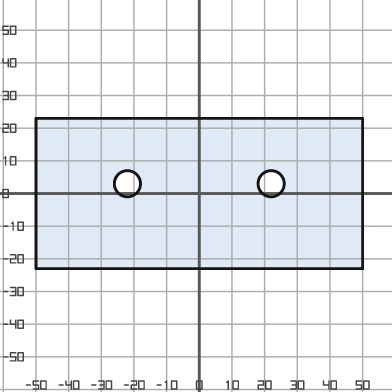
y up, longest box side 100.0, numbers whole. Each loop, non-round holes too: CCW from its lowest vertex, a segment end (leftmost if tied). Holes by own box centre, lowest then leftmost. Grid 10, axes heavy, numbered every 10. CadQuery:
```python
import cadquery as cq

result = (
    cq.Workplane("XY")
    .moveTo(-50.0, -23.0)
    .lineTo(50.0, -23.0)
    .lineTo(50.0, 23.0)
    .lineTo(-50.0, 23.0)
    .close()
    .moveTo(-22.0, 3.0)
    .circle(4.0)
    .moveTo(22.0, 3.0)
    .circle(4.0)
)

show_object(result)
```